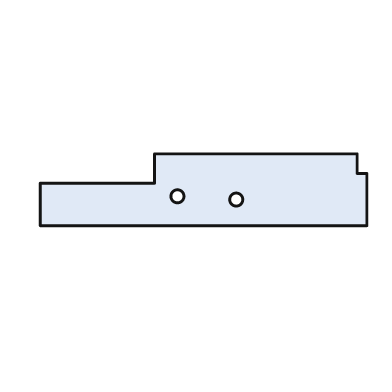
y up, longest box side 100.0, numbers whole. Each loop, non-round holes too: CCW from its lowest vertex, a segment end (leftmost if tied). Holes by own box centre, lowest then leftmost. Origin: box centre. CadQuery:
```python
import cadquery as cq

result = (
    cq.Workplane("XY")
    .moveTo(-50.0, -11.0)
    .lineTo(50.0, -11.0)
    .lineTo(50.0, 5.0)
    .lineTo(47.0, 5.0)
    .lineTo(47.0, 11.0)
    .lineTo(-15.0, 11.0)
    .lineTo(-15.0, 2.0)
    .lineTo(-50.0, 2.0)
    .close()
    .moveTo(10.0, -3.0)
    .circle(2.0)
    .moveTo(-8.0, -2.0)
    .circle(2.0)
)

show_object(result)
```